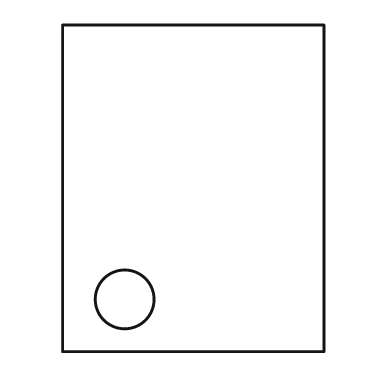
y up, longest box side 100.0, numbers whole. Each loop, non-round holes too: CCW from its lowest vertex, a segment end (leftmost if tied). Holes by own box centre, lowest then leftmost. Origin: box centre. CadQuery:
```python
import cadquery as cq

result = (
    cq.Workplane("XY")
    .moveTo(-40.0, -50.0)
    .lineTo(40.0, -50.0)
    .lineTo(40.0, 50.0)
    .lineTo(-40.0, 50.0)
    .close()
    .moveTo(-21.0, -34.0)
    .circle(9.0)
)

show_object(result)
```